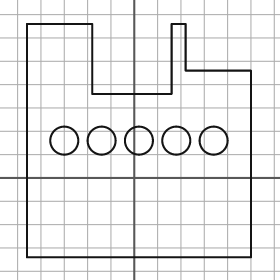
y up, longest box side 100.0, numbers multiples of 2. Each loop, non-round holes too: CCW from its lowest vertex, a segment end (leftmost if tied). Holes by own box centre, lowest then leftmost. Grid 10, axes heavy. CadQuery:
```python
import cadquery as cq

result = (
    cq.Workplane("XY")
    .moveTo(-46.0, -34.0)
    .lineTo(50.0, -34.0)
    .lineTo(50.0, 46.0)
    .lineTo(22.0, 46.0)
    .lineTo(22.0, 66.0)
    .lineTo(16.0, 66.0)
    .lineTo(16.0, 36.0)
    .lineTo(-18.0, 36.0)
    .lineTo(-18.0, 66.0)
    .lineTo(-46.0, 66.0)
    .close()
    .moveTo(-30.0, 16.0)
    .circle(6.0)
    .moveTo(-14.0, 16.0)
    .circle(6.0)
    .moveTo(2.0, 16.0)
    .circle(6.0)
    .moveTo(18.0, 16.0)
    .circle(6.0)
    .moveTo(34.0, 16.0)
    .circle(6.0)
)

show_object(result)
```